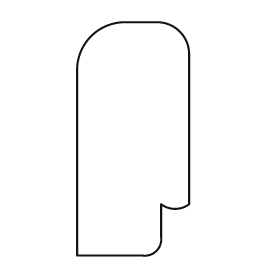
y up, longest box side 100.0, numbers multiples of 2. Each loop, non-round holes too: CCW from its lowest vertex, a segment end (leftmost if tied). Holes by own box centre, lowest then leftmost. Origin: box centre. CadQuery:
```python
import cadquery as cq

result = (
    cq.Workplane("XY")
    .moveTo(-24.0, -50.0)
    .lineTo(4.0, -50.0)
    .threePointArc((10.0, -48.0), (12.0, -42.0))
    .lineTo(12.0, -28.0)
    .threePointArc((18.0, -30.0), (24.0, -28.0))
    .lineTo(24.0, 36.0)
    .threePointArc((20.0, 46.0), (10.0, 50.0))
    .lineTo(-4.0, 50.0)
    .threePointArc((-18.0, 44.0), (-24.0, 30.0))
    .close()
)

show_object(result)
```